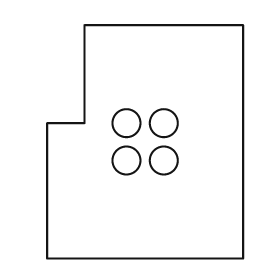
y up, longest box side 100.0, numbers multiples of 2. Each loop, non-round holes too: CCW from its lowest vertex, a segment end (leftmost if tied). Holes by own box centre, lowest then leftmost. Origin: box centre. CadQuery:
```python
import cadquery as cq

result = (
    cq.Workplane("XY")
    .moveTo(-42.0, -50.0)
    .lineTo(42.0, -50.0)
    .lineTo(42.0, 50.0)
    .lineTo(-26.0, 50.0)
    .lineTo(-26.0, 8.0)
    .lineTo(-42.0, 8.0)
    .close()
    .moveTo(-8.0, -8.0)
    .circle(6.0)
    .moveTo(8.0, -8.0)
    .circle(6.0)
    .moveTo(-8.0, 8.0)
    .circle(6.0)
    .moveTo(8.0, 8.0)
    .circle(6.0)
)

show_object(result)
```